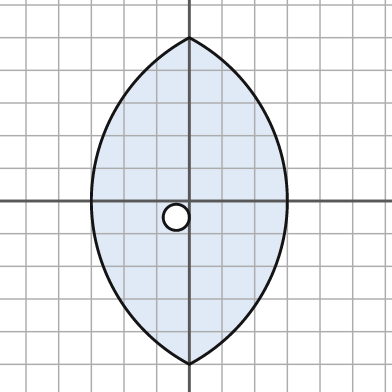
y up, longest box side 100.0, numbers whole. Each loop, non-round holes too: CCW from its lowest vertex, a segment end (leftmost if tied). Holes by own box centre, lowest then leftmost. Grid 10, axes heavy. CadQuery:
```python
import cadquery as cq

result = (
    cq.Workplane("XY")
    .moveTo(0.0, -50.0)
    .threePointArc((30.0, 0.0), (0.0, 50.0))
    .threePointArc((-30.0, 0.0), (0.0, -50.0))
    .close()
    .moveTo(-4.0, -5.0)
    .circle(4.0)
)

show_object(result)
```